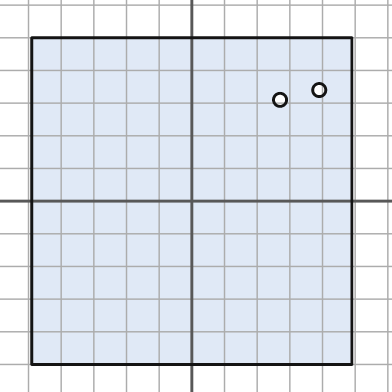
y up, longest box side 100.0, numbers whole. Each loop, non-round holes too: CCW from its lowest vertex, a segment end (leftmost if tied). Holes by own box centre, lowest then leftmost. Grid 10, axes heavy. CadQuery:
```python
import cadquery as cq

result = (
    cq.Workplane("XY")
    .moveTo(-49.0, -50.0)
    .lineTo(49.0, -50.0)
    .lineTo(49.0, 50.0)
    .lineTo(-49.0, 50.0)
    .close()
    .moveTo(27.0, 31.0)
    .circle(2.0)
    .moveTo(39.0, 34.0)
    .circle(2.0)
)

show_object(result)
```